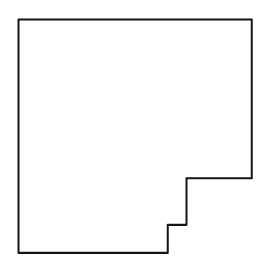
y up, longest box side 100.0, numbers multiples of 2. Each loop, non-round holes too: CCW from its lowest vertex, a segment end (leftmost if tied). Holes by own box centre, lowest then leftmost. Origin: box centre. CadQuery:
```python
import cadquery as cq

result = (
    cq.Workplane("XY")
    .moveTo(-50.0, -50.0)
    .lineTo(14.0, -50.0)
    .lineTo(14.0, -38.0)
    .lineTo(22.0, -38.0)
    .lineTo(22.0, -18.0)
    .lineTo(50.0, -18.0)
    .lineTo(50.0, 50.0)
    .lineTo(-50.0, 50.0)
    .close()
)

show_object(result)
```